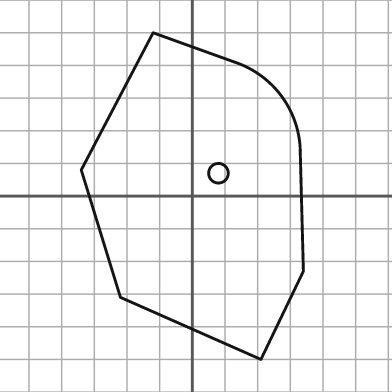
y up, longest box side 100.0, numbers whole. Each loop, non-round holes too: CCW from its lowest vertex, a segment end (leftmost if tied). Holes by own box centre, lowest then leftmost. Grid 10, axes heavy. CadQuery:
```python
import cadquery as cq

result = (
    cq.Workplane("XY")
    .moveTo(21.0, -50.0)
    .lineTo(34.0, -23.0)
    .lineTo(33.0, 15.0)
    .threePointArc((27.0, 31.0), (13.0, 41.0))
    .lineTo(-12.0, 50.0)
    .lineTo(-34.0, 8.0)
    .lineTo(-22.0, -31.0)
    .close()
    .moveTo(8.0, 7.0)
    .circle(3.0)
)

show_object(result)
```